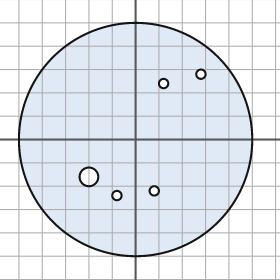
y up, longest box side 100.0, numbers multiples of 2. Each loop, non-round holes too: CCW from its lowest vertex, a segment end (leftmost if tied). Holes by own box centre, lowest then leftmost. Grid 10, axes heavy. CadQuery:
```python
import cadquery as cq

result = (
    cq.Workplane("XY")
    .moveTo(0.0, 0.0)
    .circle(50.0)
    .moveTo(-8.0, -24.0)
    .circle(2.0)
    .moveTo(8.0, -22.0)
    .circle(2.0)
    .moveTo(-20.0, -16.0)
    .circle(4.0)
    .moveTo(12.0, 24.0)
    .circle(2.0)
    .moveTo(28.0, 28.0)
    .circle(2.0)
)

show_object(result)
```